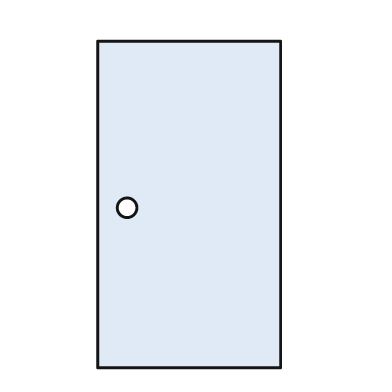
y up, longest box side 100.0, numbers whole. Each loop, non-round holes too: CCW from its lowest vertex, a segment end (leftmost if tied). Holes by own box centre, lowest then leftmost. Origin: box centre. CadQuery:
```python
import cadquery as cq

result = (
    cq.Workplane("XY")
    .moveTo(-28.0, -50.0)
    .lineTo(28.0, -50.0)
    .lineTo(28.0, 50.0)
    .lineTo(-28.0, 50.0)
    .close()
    .moveTo(-19.0, -1.0)
    .circle(3.0)
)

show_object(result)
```